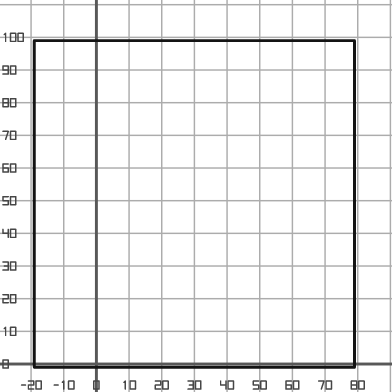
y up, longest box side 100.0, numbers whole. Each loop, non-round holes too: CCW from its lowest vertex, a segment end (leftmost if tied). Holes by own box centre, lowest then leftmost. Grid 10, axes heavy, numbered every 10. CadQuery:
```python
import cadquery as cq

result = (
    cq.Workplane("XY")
    .moveTo(-19.0, -1.0)
    .lineTo(79.0, -1.0)
    .lineTo(79.0, 99.0)
    .lineTo(-19.0, 99.0)
    .close()
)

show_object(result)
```